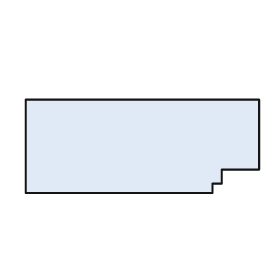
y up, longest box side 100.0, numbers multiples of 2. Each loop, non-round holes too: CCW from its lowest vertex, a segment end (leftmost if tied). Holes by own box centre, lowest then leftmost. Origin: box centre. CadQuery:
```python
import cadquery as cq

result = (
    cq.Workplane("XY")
    .moveTo(-50.0, -20.0)
    .lineTo(30.0, -20.0)
    .lineTo(30.0, -16.0)
    .lineTo(34.0, -16.0)
    .lineTo(34.0, -10.0)
    .lineTo(50.0, -10.0)
    .lineTo(50.0, 20.0)
    .lineTo(-50.0, 20.0)
    .close()
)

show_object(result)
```